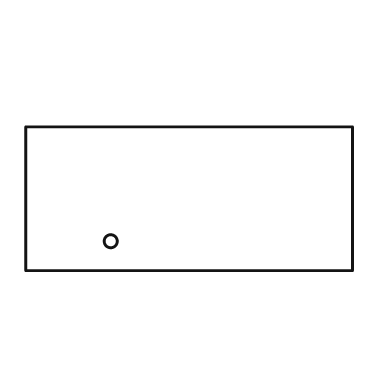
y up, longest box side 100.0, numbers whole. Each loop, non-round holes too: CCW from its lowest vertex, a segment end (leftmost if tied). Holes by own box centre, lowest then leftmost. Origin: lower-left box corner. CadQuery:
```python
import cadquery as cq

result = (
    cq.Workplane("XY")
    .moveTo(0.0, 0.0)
    .lineTo(100.0, 0.0)
    .lineTo(100.0, 44.0)
    .lineTo(0.0, 44.0)
    .close()
    .moveTo(26.0, 9.0)
    .circle(2.0)
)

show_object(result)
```